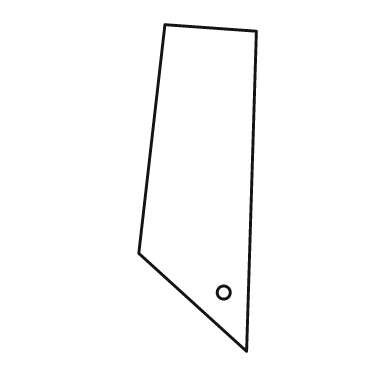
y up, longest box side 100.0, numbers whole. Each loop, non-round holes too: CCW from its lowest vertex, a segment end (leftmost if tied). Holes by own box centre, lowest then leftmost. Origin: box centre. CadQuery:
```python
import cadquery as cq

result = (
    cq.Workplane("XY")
    .moveTo(15.0, -50.0)
    .lineTo(18.0, 48.0)
    .lineTo(-10.0, 50.0)
    .lineTo(-18.0, -20.0)
    .close()
    .moveTo(8.0, -32.0)
    .circle(2.0)
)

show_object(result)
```